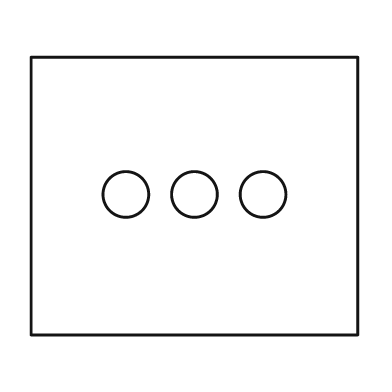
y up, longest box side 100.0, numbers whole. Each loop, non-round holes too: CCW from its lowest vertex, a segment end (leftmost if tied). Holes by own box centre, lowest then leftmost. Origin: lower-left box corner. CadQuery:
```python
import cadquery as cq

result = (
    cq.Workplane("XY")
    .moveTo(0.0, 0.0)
    .lineTo(100.0, 0.0)
    .lineTo(100.0, 85.0)
    .lineTo(0.0, 85.0)
    .close()
    .moveTo(29.0, 43.0)
    .circle(7.0)
    .moveTo(50.0, 43.0)
    .circle(7.0)
    .moveTo(71.0, 43.0)
    .circle(7.0)
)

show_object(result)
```